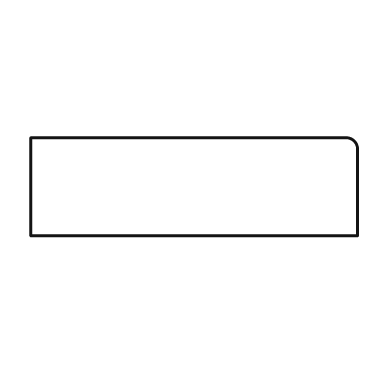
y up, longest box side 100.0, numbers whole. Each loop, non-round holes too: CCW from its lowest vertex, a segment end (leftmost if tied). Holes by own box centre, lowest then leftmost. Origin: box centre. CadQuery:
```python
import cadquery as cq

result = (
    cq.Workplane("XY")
    .moveTo(-50.0, -15.0)
    .lineTo(50.0, -15.0)
    .lineTo(50.0, 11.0)
    .threePointArc((49.0, 14.0), (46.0, 15.0))
    .lineTo(-50.0, 15.0)
    .close()
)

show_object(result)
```